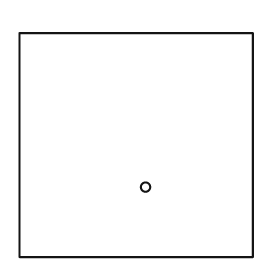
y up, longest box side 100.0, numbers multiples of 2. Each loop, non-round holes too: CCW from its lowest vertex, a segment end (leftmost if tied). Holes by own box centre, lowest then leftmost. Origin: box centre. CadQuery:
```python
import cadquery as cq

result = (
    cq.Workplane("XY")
    .moveTo(-50.0, -48.0)
    .lineTo(50.0, -48.0)
    .lineTo(50.0, 48.0)
    .lineTo(-50.0, 48.0)
    .close()
    .moveTo(4.0, -18.0)
    .circle(2.0)
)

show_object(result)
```